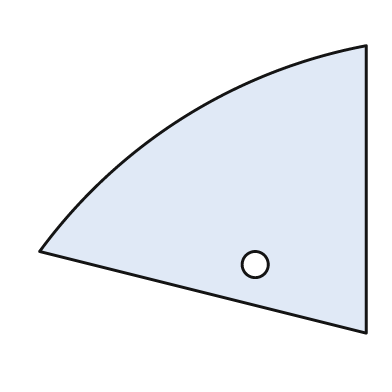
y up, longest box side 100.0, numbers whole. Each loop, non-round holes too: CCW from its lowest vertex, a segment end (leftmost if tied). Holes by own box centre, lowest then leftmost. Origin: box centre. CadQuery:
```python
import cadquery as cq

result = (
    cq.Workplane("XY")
    .moveTo(50.0, -44.0)
    .lineTo(50.0, 44.0)
    .threePointArc((-6.0, 22.0), (-50.0, -19.0))
    .close()
    .moveTo(16.0, -23.0)
    .circle(4.0)
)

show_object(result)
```